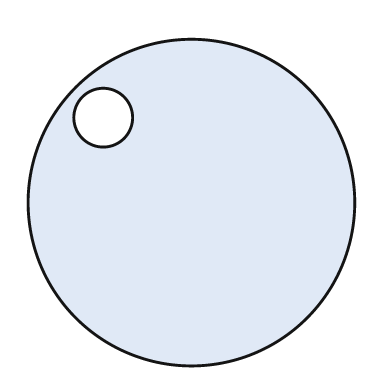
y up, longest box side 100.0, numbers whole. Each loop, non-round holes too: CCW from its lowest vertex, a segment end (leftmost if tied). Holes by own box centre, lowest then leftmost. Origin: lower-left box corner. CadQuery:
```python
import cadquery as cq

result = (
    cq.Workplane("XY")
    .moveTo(50.0, 50.0)
    .circle(50.0)
    .moveTo(23.0, 76.0)
    .circle(9.0)
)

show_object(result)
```